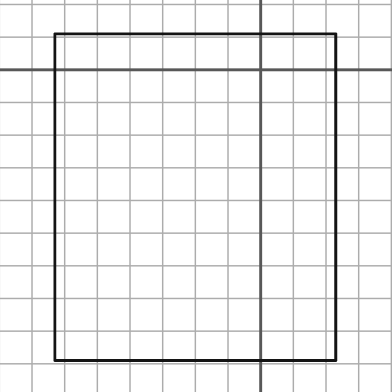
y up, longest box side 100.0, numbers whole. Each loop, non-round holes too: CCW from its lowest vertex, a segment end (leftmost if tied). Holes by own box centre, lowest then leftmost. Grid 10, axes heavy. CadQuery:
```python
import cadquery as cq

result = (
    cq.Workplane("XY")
    .moveTo(-63.0, -89.0)
    .lineTo(23.0, -89.0)
    .lineTo(23.0, 11.0)
    .lineTo(-63.0, 11.0)
    .close()
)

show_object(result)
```